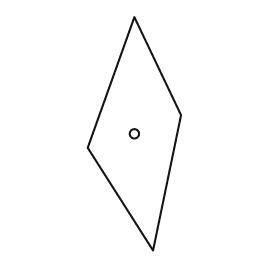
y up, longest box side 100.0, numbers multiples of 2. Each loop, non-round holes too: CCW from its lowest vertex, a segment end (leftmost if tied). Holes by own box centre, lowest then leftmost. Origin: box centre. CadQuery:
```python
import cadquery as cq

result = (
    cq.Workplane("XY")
    .moveTo(8.0, -50.0)
    .lineTo(20.0, 8.0)
    .lineTo(0.0, 50.0)
    .lineTo(-20.0, -6.0)
    .close()
    .moveTo(0.0, 0.0)
    .circle(2.0)
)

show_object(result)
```